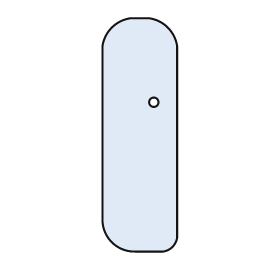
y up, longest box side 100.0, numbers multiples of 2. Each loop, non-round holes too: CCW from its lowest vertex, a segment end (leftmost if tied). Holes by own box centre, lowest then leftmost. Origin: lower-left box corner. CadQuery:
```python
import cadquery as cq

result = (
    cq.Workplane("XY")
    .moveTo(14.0, 0.0)
    .lineTo(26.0, 0.0)
    .threePointArc((30.0, 2.0), (32.0, 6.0))
    .lineTo(32.0, 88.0)
    .threePointArc((28.0, 96.0), (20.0, 100.0))
    .lineTo(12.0, 100.0)
    .threePointArc((4.0, 96.0), (0.0, 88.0))
    .lineTo(0.0, 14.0)
    .threePointArc((4.0, 4.0), (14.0, 0.0))
    .close()
    .moveTo(22.0, 64.0)
    .circle(2.0)
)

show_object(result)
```